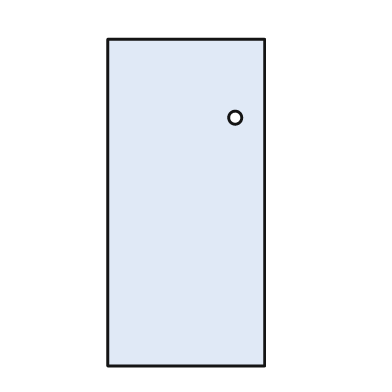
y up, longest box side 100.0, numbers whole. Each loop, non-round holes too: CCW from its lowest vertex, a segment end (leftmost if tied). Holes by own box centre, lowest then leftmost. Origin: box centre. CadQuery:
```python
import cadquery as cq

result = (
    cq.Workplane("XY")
    .moveTo(-24.0, -50.0)
    .lineTo(24.0, -50.0)
    .lineTo(24.0, 50.0)
    .lineTo(-24.0, 50.0)
    .close()
    .moveTo(15.0, 26.0)
    .circle(2.0)
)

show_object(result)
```